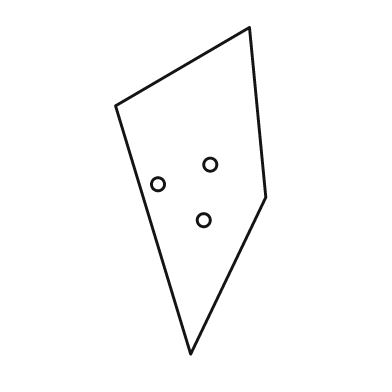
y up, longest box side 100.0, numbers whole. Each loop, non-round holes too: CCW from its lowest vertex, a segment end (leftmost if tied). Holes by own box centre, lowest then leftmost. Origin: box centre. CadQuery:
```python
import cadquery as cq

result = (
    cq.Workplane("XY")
    .moveTo(0.0, -50.0)
    .lineTo(23.0, -2.0)
    .lineTo(18.0, 50.0)
    .lineTo(-23.0, 26.0)
    .close()
    .moveTo(4.0, -9.0)
    .circle(2.0)
    .moveTo(-10.0, 2.0)
    .circle(2.0)
    .moveTo(6.0, 8.0)
    .circle(2.0)
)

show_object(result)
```